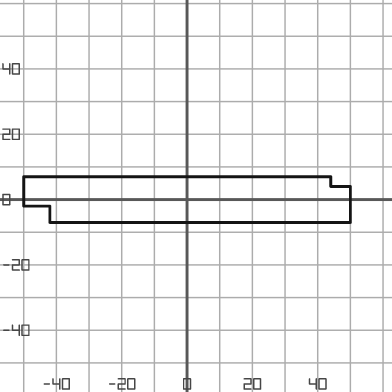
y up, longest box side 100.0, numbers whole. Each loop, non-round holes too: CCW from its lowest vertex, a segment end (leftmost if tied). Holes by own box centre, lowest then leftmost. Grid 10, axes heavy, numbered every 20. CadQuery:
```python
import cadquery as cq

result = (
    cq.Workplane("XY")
    .moveTo(-42.0, -7.0)
    .lineTo(50.0, -7.0)
    .lineTo(50.0, 4.0)
    .lineTo(44.0, 4.0)
    .lineTo(44.0, 7.0)
    .lineTo(-50.0, 7.0)
    .lineTo(-50.0, -2.0)
    .lineTo(-42.0, -2.0)
    .close()
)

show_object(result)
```